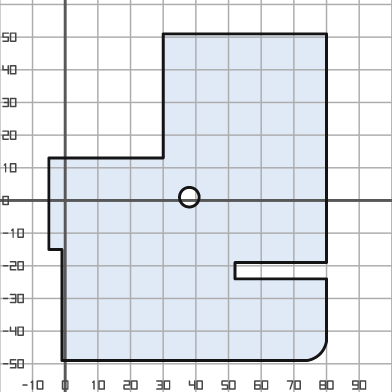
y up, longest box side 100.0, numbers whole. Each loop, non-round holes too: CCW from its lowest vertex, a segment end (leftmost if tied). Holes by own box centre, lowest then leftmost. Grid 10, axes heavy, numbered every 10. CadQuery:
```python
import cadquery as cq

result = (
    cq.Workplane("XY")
    .moveTo(-1.0, -49.0)
    .lineTo(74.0, -49.0)
    .threePointArc((78.0, -47.0), (80.0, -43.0))
    .lineTo(80.0, -24.0)
    .lineTo(52.0, -24.0)
    .lineTo(52.0, -19.0)
    .lineTo(80.0, -19.0)
    .lineTo(80.0, 51.0)
    .lineTo(30.0, 51.0)
    .lineTo(30.0, 13.0)
    .lineTo(-5.0, 13.0)
    .lineTo(-5.0, -15.0)
    .lineTo(-1.0, -15.0)
    .close()
    .moveTo(38.0, 1.0)
    .circle(3.0)
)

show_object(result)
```